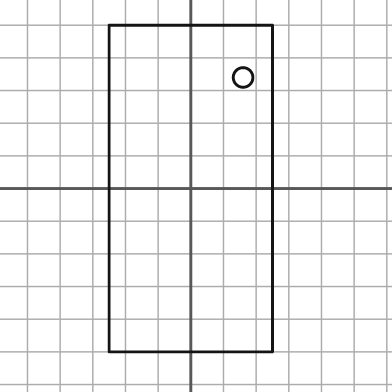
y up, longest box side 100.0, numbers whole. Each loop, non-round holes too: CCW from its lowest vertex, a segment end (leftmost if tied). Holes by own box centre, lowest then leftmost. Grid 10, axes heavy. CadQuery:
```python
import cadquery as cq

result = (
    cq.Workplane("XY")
    .moveTo(-25.0, -50.0)
    .lineTo(25.0, -50.0)
    .lineTo(25.0, 50.0)
    .lineTo(-25.0, 50.0)
    .close()
    .moveTo(16.0, 34.0)
    .circle(3.0)
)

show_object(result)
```